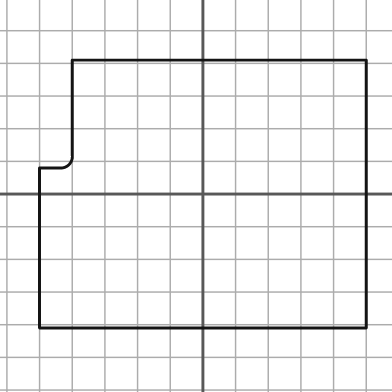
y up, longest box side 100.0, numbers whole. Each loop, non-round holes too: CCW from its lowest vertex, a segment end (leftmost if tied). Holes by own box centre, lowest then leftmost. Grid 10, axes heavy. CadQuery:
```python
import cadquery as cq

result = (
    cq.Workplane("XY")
    .moveTo(-50.0, -41.0)
    .lineTo(50.0, -41.0)
    .lineTo(50.0, 41.0)
    .lineTo(-40.0, 41.0)
    .lineTo(-40.0, 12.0)
    .threePointArc((-41.0, 9.0), (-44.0, 8.0))
    .lineTo(-50.0, 8.0)
    .close()
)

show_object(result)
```